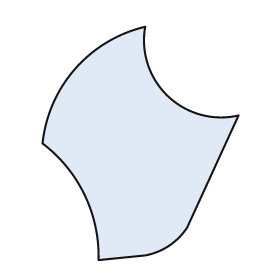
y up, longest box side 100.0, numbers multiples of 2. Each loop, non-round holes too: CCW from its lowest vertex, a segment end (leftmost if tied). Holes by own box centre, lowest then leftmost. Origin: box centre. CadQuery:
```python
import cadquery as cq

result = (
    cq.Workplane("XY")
    .moveTo(-18.0, -50.0)
    .lineTo(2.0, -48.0)
    .threePointArc((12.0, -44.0), (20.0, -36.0))
    .lineTo(42.0, 12.0)
    .threePointArc((12.0, 20.0), (2.0, 50.0))
    .threePointArc((-28.0, 32.0), (-42.0, 0.0))
    .threePointArc((-24.0, -22.0), (-18.0, -50.0))
    .close()
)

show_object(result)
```